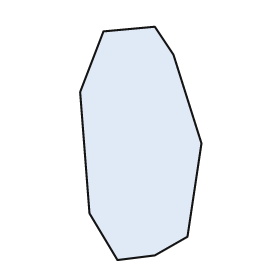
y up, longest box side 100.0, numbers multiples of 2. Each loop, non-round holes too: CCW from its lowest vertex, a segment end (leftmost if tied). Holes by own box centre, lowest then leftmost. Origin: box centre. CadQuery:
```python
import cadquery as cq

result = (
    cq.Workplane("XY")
    .moveTo(-10.0, -50.0)
    .lineTo(6.0, -48.0)
    .lineTo(20.0, -40.0)
    .lineTo(26.0, 0.0)
    .lineTo(14.0, 38.0)
    .lineTo(6.0, 50.0)
    .lineTo(-16.0, 48.0)
    .lineTo(-26.0, 22.0)
    .lineTo(-22.0, -30.0)
    .close()
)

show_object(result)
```